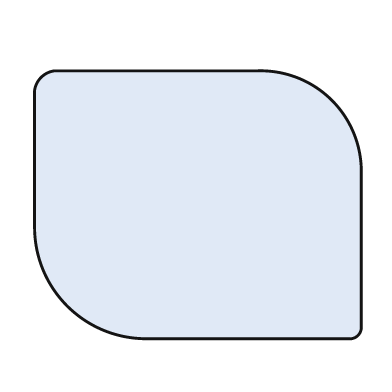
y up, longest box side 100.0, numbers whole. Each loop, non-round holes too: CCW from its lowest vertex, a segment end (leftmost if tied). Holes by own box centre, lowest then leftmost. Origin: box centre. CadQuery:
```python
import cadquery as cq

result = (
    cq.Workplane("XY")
    .moveTo(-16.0, -41.0)
    .lineTo(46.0, -41.0)
    .threePointArc((49.0, -40.0), (50.0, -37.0))
    .lineTo(50.0, 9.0)
    .threePointArc((41.0, 32.0), (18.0, 41.0))
    .lineTo(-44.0, 41.0)
    .threePointArc((-48.0, 39.0), (-50.0, 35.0))
    .lineTo(-50.0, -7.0)
    .threePointArc((-40.0, -31.0), (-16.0, -41.0))
    .close()
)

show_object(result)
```